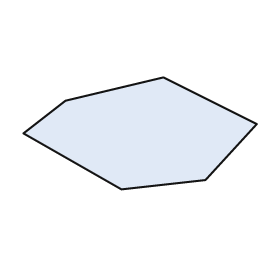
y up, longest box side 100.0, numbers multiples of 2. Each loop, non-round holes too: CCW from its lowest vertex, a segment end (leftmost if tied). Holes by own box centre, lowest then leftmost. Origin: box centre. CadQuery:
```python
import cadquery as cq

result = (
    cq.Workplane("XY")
    .moveTo(-8.0, -24.0)
    .lineTo(28.0, -20.0)
    .lineTo(50.0, 4.0)
    .lineTo(10.0, 24.0)
    .lineTo(-32.0, 14.0)
    .lineTo(-50.0, 0.0)
    .close()
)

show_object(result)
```